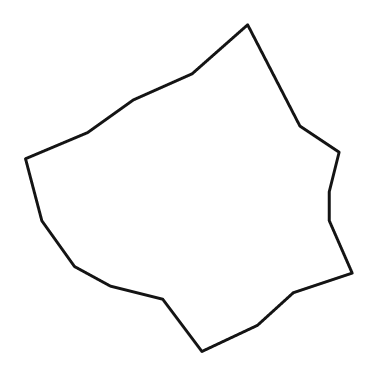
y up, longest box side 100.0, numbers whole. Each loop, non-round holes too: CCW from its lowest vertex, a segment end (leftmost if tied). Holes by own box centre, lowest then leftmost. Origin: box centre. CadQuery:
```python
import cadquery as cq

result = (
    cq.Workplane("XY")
    .moveTo(4.0, -50.0)
    .lineTo(21.0, -42.0)
    .lineTo(32.0, -32.0)
    .lineTo(50.0, -26.0)
    .lineTo(43.0, -10.0)
    .lineTo(43.0, -1.0)
    .lineTo(46.0, 11.0)
    .lineTo(34.0, 19.0)
    .lineTo(18.0, 50.0)
    .lineTo(1.0, 35.0)
    .lineTo(-17.0, 27.0)
    .lineTo(-31.0, 17.0)
    .lineTo(-50.0, 9.0)
    .lineTo(-45.0, -10.0)
    .lineTo(-35.0, -24.0)
    .lineTo(-24.0, -30.0)
    .lineTo(-8.0, -34.0)
    .close()
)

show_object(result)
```